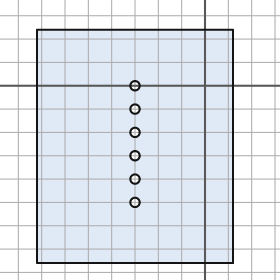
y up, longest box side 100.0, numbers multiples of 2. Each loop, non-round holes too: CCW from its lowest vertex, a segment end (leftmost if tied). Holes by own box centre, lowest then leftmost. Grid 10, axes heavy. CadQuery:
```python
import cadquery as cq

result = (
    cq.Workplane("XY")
    .moveTo(-72.0, -76.0)
    .lineTo(12.0, -76.0)
    .lineTo(12.0, 24.0)
    .lineTo(-72.0, 24.0)
    .close()
    .moveTo(-30.0, -50.0)
    .circle(2.0)
    .moveTo(-30.0, -40.0)
    .circle(2.0)
    .moveTo(-30.0, -30.0)
    .circle(2.0)
    .moveTo(-30.0, -20.0)
    .circle(2.0)
    .moveTo(-30.0, -10.0)
    .circle(2.0)
    .moveTo(-30.0, 0.0)
    .circle(2.0)
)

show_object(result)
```